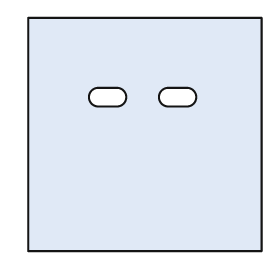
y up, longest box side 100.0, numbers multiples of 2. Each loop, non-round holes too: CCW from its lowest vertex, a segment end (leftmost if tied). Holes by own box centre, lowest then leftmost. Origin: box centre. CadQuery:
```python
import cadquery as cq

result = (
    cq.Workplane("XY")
    .moveTo(-50.0, -50.0)
    .lineTo(50.0, -50.0)
    .lineTo(50.0, 50.0)
    .lineTo(-50.0, 50.0)
    .close()
    .moveTo(-20.0, 12.0)
    .lineTo(-12.0, 12.0)
    .threePointArc((-8.0, 16.0), (-12.0, 20.0))
    .lineTo(-20.0, 20.0)
    .threePointArc((-24.0, 16.0), (-20.0, 12.0))
    .close()
    .moveTo(10.0, 12.0)
    .lineTo(18.0, 12.0)
    .threePointArc((22.0, 16.0), (18.0, 20.0))
    .lineTo(10.0, 20.0)
    .threePointArc((6.0, 16.0), (10.0, 12.0))
    .close()
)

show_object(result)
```